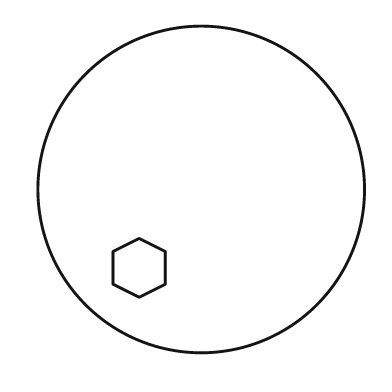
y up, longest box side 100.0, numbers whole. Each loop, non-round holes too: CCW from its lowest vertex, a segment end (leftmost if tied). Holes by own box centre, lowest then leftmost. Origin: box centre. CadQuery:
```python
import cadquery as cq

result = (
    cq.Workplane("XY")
    .moveTo(0.0, 0.0)
    .circle(50.0)
    .moveTo(-19.0, -33.0)
    .lineTo(-11.0, -29.0)
    .lineTo(-11.0, -19.0)
    .lineTo(-19.0, -15.0)
    .lineTo(-27.0, -19.0)
    .lineTo(-27.0, -29.0)
    .close()
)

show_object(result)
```